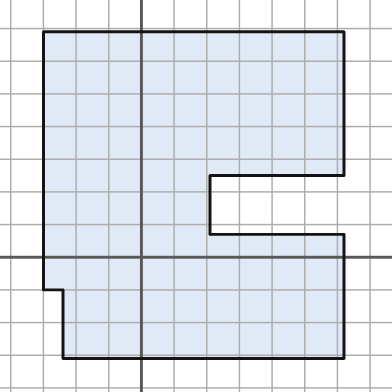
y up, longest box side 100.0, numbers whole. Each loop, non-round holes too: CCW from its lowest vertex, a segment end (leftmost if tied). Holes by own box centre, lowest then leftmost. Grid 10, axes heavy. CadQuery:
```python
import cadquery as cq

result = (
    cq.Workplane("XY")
    .moveTo(-24.0, -31.0)
    .lineTo(62.0, -31.0)
    .lineTo(62.0, 7.0)
    .lineTo(21.0, 7.0)
    .lineTo(21.0, 25.0)
    .lineTo(62.0, 25.0)
    .lineTo(62.0, 69.0)
    .lineTo(-30.0, 69.0)
    .lineTo(-30.0, -10.0)
    .lineTo(-24.0, -10.0)
    .close()
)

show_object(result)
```